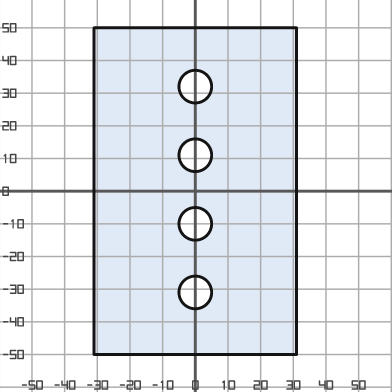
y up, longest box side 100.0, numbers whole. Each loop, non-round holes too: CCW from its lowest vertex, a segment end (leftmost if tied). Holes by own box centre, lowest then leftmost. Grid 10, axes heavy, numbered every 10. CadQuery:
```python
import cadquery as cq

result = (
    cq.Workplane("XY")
    .moveTo(-31.0, -50.0)
    .lineTo(31.0, -50.0)
    .lineTo(31.0, 50.0)
    .lineTo(-31.0, 50.0)
    .close()
    .moveTo(0.0, -31.0)
    .circle(5.0)
    .moveTo(0.0, -10.0)
    .circle(5.0)
    .moveTo(0.0, 11.0)
    .circle(5.0)
    .moveTo(0.0, 32.0)
    .circle(5.0)
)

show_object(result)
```